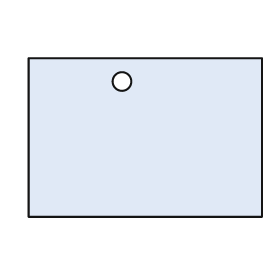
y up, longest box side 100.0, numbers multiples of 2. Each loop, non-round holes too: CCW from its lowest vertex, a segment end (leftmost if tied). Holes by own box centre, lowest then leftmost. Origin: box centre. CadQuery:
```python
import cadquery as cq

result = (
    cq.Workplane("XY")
    .moveTo(-50.0, -34.0)
    .lineTo(50.0, -34.0)
    .lineTo(50.0, 34.0)
    .lineTo(-50.0, 34.0)
    .close()
    .moveTo(-10.0, 24.0)
    .circle(4.0)
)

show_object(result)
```